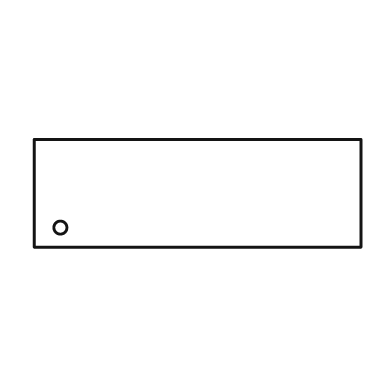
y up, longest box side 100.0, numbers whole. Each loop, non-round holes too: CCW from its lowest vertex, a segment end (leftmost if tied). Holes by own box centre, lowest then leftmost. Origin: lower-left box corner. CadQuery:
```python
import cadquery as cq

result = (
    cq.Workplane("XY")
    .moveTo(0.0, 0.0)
    .lineTo(100.0, 0.0)
    .lineTo(100.0, 33.0)
    .lineTo(0.0, 33.0)
    .close()
    .moveTo(8.0, 6.0)
    .circle(2.0)
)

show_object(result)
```